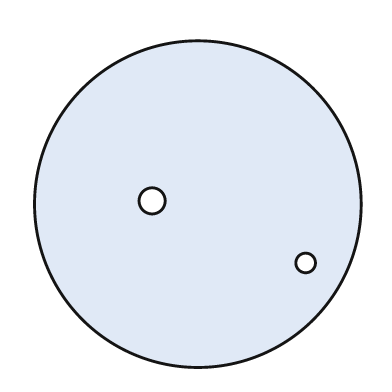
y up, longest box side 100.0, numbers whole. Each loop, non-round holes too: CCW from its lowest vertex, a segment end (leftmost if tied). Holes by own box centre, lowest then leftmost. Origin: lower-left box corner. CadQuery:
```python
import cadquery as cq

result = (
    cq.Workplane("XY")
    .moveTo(50.0, 50.0)
    .circle(50.0)
    .moveTo(83.0, 32.0)
    .circle(3.0)
    .moveTo(36.0, 51.0)
    .circle(4.0)
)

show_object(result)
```